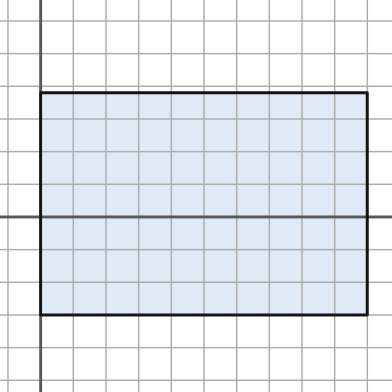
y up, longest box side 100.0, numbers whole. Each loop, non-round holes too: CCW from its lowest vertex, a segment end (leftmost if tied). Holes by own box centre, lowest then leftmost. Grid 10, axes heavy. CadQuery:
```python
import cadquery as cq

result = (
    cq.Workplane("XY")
    .moveTo(0.0, -30.0)
    .lineTo(100.0, -30.0)
    .lineTo(100.0, 38.0)
    .lineTo(0.0, 38.0)
    .close()
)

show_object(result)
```